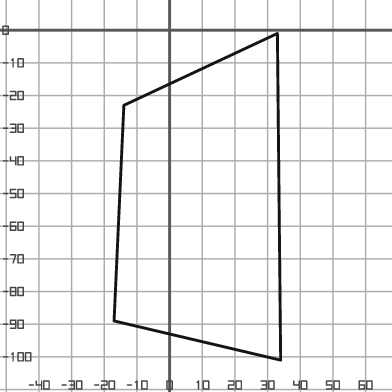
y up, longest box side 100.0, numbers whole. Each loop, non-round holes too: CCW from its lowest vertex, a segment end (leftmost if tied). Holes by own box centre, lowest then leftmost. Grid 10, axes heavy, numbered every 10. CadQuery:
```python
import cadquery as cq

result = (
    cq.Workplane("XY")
    .moveTo(34.0, -101.0)
    .lineTo(33.0, -1.0)
    .lineTo(-14.0, -23.0)
    .lineTo(-17.0, -89.0)
    .close()
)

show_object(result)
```